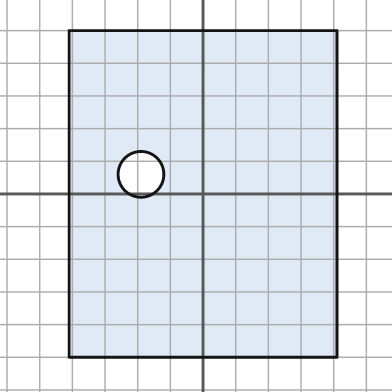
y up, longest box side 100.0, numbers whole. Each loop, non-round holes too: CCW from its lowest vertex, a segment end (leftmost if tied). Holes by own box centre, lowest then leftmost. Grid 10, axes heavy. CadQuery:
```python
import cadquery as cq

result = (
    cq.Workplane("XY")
    .moveTo(-41.0, -50.0)
    .lineTo(41.0, -50.0)
    .lineTo(41.0, 50.0)
    .lineTo(-41.0, 50.0)
    .close()
    .moveTo(-19.0, 6.0)
    .circle(7.0)
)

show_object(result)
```